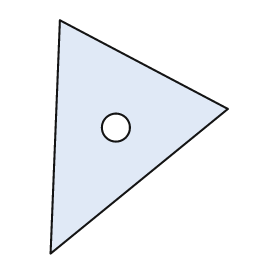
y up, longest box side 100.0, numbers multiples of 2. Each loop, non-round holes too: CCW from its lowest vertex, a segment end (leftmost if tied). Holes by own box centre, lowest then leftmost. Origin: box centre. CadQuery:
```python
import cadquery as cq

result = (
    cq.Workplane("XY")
    .moveTo(-38.0, -50.0)
    .lineTo(38.0, 12.0)
    .lineTo(-34.0, 50.0)
    .close()
    .moveTo(-10.0, 4.0)
    .circle(6.0)
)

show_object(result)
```